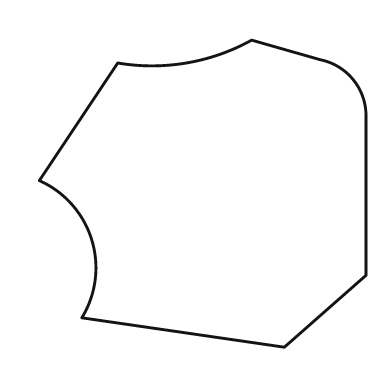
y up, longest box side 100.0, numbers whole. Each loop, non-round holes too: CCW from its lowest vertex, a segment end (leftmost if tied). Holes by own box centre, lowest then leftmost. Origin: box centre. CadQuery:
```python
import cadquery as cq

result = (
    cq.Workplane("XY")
    .moveTo(25.0, -47.0)
    .lineTo(50.0, -25.0)
    .lineTo(50.0, 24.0)
    .threePointArc((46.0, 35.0), (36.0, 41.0))
    .lineTo(15.0, 47.0)
    .threePointArc((-5.0, 40.0), (-26.0, 40.0))
    .lineTo(-50.0, 4.0)
    .threePointArc((-34.0, -14.0), (-37.0, -38.0))
    .close()
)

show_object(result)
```